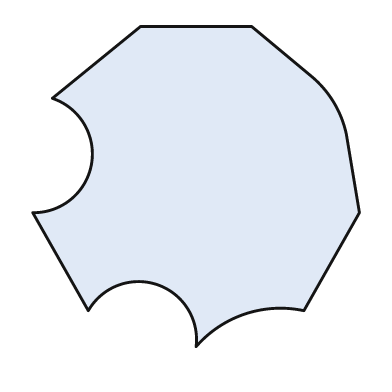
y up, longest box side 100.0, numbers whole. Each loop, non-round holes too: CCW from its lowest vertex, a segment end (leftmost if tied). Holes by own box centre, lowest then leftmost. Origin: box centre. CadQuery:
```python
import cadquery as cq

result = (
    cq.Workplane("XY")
    .moveTo(0.0, -49.0)
    .threePointArc((15.0, -39.0), (33.0, -38.0))
    .lineTo(50.0, -8.0)
    .lineTo(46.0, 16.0)
    .threePointArc((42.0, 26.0), (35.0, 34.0))
    .lineTo(17.0, 49.0)
    .lineTo(-17.0, 49.0)
    .lineTo(-44.0, 27.0)
    .threePointArc((-32.0, 7.0), (-50.0, -8.0))
    .lineTo(-33.0, -38.0)
    .threePointArc((-12.0, -30.0), (0.0, -49.0))
    .close()
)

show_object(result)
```